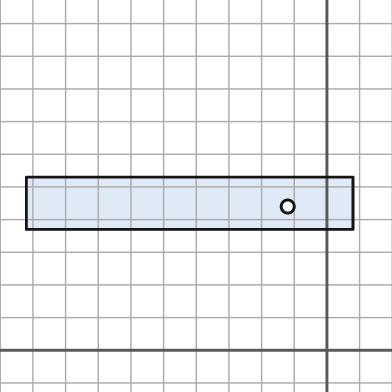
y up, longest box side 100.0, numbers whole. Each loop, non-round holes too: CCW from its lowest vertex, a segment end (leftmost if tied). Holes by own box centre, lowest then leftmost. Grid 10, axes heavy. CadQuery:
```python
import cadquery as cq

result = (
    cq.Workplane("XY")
    .moveTo(-92.0, 37.0)
    .lineTo(8.0, 37.0)
    .lineTo(8.0, 53.0)
    .lineTo(-92.0, 53.0)
    .close()
    .moveTo(-12.0, 44.0)
    .circle(2.0)
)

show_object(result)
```